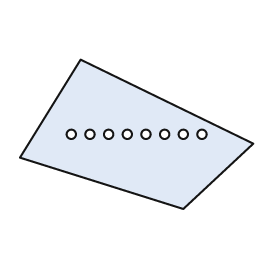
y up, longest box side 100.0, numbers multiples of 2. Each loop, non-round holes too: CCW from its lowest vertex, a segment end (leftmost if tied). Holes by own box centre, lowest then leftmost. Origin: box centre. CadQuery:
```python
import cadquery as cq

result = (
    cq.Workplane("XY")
    .moveTo(20.0, -32.0)
    .lineTo(50.0, -4.0)
    .lineTo(-24.0, 32.0)
    .lineTo(-50.0, -10.0)
    .close()
    .moveTo(-28.0, 0.0)
    .circle(2.0)
    .moveTo(-20.0, 0.0)
    .circle(2.0)
    .moveTo(-12.0, 0.0)
    .circle(2.0)
    .moveTo(-4.0, 0.0)
    .circle(2.0)
    .moveTo(4.0, 0.0)
    .circle(2.0)
    .moveTo(12.0, 0.0)
    .circle(2.0)
    .moveTo(20.0, 0.0)
    .circle(2.0)
    .moveTo(28.0, 0.0)
    .circle(2.0)
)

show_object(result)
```